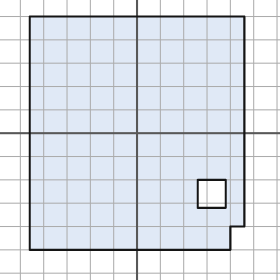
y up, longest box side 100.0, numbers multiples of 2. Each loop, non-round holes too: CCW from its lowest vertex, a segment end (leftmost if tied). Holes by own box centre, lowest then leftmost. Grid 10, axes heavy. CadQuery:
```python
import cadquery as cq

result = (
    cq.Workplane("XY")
    .moveTo(-46.0, -50.0)
    .lineTo(40.0, -50.0)
    .lineTo(40.0, -40.0)
    .lineTo(46.0, -40.0)
    .lineTo(46.0, 50.0)
    .lineTo(-46.0, 50.0)
    .close()
    .moveTo(26.0, -32.0)
    .lineTo(38.0, -32.0)
    .lineTo(38.0, -20.0)
    .lineTo(26.0, -20.0)
    .close()
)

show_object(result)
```